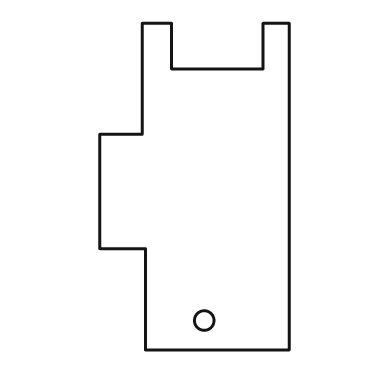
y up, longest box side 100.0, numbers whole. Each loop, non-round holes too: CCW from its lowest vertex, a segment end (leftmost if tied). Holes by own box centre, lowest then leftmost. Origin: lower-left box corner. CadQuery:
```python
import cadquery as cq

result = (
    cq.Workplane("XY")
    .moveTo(14.0, 0.0)
    .lineTo(58.0, 0.0)
    .lineTo(58.0, 100.0)
    .lineTo(50.0, 100.0)
    .lineTo(50.0, 86.0)
    .lineTo(22.0, 86.0)
    .lineTo(22.0, 100.0)
    .lineTo(13.0, 100.0)
    .lineTo(13.0, 66.0)
    .lineTo(0.0, 66.0)
    .lineTo(0.0, 31.0)
    .lineTo(14.0, 31.0)
    .close()
    .moveTo(32.0, 9.0)
    .circle(3.0)
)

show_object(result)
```